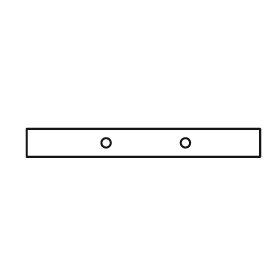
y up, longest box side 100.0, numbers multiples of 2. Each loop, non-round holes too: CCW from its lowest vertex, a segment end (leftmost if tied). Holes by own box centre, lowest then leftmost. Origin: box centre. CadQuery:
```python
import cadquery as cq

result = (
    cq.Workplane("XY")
    .moveTo(-50.0, -6.0)
    .lineTo(50.0, -6.0)
    .lineTo(50.0, 6.0)
    .lineTo(-50.0, 6.0)
    .close()
    .moveTo(-16.0, 0.0)
    .circle(2.0)
    .moveTo(18.0, 0.0)
    .circle(2.0)
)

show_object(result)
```